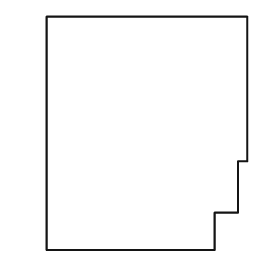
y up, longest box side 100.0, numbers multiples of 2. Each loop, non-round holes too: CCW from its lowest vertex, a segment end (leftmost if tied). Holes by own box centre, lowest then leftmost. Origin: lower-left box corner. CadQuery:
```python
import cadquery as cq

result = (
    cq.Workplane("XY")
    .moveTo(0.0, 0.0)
    .lineTo(72.0, 0.0)
    .lineTo(72.0, 16.0)
    .lineTo(82.0, 16.0)
    .lineTo(82.0, 38.0)
    .lineTo(86.0, 38.0)
    .lineTo(86.0, 100.0)
    .lineTo(0.0, 100.0)
    .close()
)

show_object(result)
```